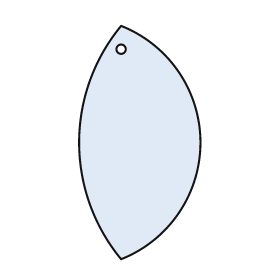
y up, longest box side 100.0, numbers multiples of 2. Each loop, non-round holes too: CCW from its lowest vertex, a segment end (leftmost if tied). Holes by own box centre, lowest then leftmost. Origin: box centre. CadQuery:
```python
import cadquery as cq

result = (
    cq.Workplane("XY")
    .moveTo(-8.0, -50.0)
    .threePointArc((26.0, 0.0), (-8.0, 50.0))
    .threePointArc((-26.0, 0.0), (-8.0, -50.0))
    .close()
    .moveTo(-8.0, 40.0)
    .circle(2.0)
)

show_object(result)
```